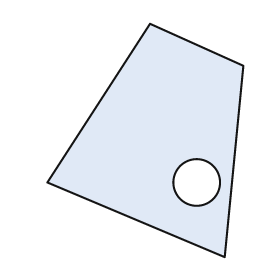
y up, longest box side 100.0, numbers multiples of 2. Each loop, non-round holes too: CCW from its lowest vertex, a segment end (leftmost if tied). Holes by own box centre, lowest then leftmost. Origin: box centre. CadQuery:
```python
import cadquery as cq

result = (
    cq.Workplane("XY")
    .moveTo(34.0, -50.0)
    .lineTo(42.0, 32.0)
    .lineTo(2.0, 50.0)
    .lineTo(-42.0, -18.0)
    .close()
    .moveTo(22.0, -18.0)
    .circle(10.0)
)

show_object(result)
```